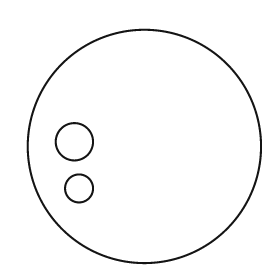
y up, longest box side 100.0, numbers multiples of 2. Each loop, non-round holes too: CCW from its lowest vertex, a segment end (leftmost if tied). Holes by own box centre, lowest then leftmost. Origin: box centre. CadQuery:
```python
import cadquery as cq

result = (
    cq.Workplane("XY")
    .moveTo(0.0, 0.0)
    .circle(50.0)
    .moveTo(-28.0, -18.0)
    .circle(6.0)
    .moveTo(-30.0, 2.0)
    .circle(8.0)
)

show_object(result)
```